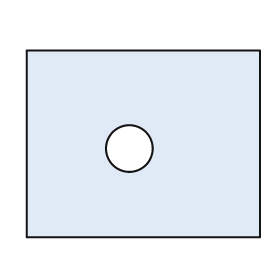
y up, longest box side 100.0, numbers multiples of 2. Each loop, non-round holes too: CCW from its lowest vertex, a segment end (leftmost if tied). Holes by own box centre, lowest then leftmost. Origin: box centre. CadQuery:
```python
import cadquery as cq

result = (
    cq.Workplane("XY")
    .moveTo(-50.0, -40.0)
    .lineTo(50.0, -40.0)
    .lineTo(50.0, 40.0)
    .lineTo(-50.0, 40.0)
    .close()
    .moveTo(-6.0, -2.0)
    .circle(10.0)
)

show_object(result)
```